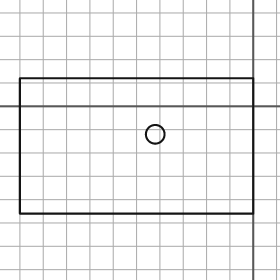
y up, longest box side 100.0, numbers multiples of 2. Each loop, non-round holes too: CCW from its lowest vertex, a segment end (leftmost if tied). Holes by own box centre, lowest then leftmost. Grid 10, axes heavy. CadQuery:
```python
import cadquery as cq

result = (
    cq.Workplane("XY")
    .moveTo(-100.0, -46.0)
    .lineTo(0.0, -46.0)
    .lineTo(0.0, 12.0)
    .lineTo(-100.0, 12.0)
    .close()
    .moveTo(-42.0, -12.0)
    .circle(4.0)
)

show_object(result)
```